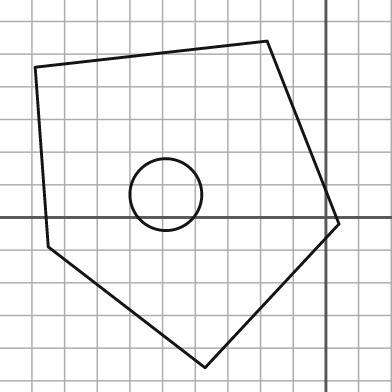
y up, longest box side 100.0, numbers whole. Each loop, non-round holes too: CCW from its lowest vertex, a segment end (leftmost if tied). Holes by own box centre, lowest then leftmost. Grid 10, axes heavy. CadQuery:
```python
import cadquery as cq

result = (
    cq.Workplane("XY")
    .moveTo(-37.0, -46.0)
    .lineTo(4.0, -2.0)
    .lineTo(-18.0, 54.0)
    .lineTo(-89.0, 46.0)
    .lineTo(-85.0, -9.0)
    .close()
    .moveTo(-49.0, 7.0)
    .circle(11.0)
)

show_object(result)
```